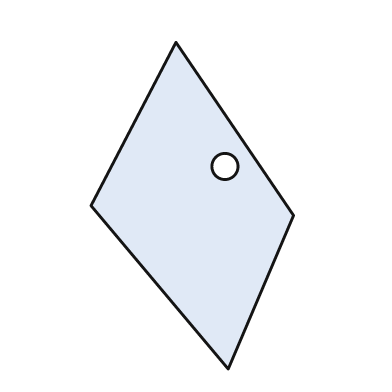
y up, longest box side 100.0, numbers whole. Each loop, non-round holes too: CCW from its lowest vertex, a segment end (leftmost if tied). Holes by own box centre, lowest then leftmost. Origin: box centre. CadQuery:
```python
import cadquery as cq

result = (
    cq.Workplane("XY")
    .moveTo(11.0, -50.0)
    .lineTo(31.0, -3.0)
    .lineTo(-5.0, 50.0)
    .lineTo(-31.0, 0.0)
    .close()
    .moveTo(10.0, 12.0)
    .circle(4.0)
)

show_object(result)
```